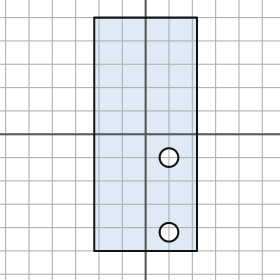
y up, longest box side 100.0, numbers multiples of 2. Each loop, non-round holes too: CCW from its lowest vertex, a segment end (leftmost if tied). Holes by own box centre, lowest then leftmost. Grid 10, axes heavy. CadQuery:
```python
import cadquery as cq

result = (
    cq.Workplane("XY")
    .moveTo(-22.0, -50.0)
    .lineTo(22.0, -50.0)
    .lineTo(22.0, 50.0)
    .lineTo(-22.0, 50.0)
    .close()
    .moveTo(10.0, -42.0)
    .circle(4.0)
    .moveTo(10.0, -10.0)
    .circle(4.0)
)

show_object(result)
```